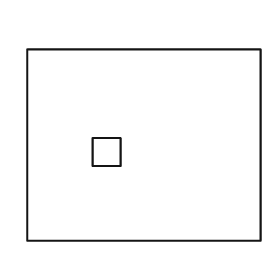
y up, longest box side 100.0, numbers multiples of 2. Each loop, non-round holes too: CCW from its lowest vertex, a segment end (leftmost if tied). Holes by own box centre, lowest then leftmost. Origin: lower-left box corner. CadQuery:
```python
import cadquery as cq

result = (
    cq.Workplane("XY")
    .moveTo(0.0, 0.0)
    .lineTo(100.0, 0.0)
    .lineTo(100.0, 82.0)
    .lineTo(0.0, 82.0)
    .close()
    .moveTo(28.0, 32.0)
    .lineTo(40.0, 32.0)
    .lineTo(40.0, 44.0)
    .lineTo(28.0, 44.0)
    .close()
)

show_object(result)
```